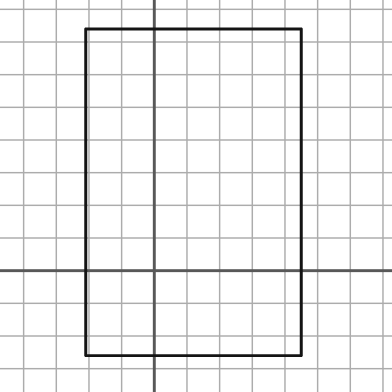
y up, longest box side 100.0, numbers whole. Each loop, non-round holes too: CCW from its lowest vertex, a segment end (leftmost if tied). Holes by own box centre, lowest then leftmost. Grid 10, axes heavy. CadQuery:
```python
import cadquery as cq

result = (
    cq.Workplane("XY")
    .moveTo(-21.0, -26.0)
    .lineTo(45.0, -26.0)
    .lineTo(45.0, 74.0)
    .lineTo(-21.0, 74.0)
    .close()
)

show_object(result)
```